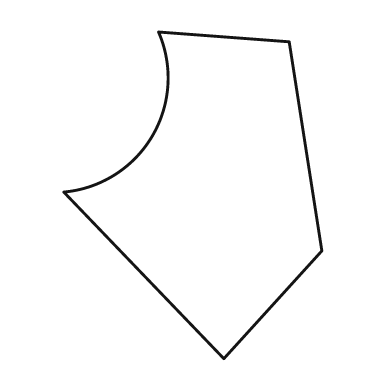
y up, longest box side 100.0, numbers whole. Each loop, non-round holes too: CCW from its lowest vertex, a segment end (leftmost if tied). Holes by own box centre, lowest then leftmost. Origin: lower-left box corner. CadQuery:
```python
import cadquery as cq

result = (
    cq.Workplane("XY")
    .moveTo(49.0, 0.0)
    .lineTo(79.0, 33.0)
    .lineTo(69.0, 97.0)
    .lineTo(29.0, 100.0)
    .threePointArc((27.0, 68.0), (0.0, 51.0))
    .close()
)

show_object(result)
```